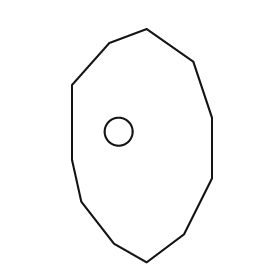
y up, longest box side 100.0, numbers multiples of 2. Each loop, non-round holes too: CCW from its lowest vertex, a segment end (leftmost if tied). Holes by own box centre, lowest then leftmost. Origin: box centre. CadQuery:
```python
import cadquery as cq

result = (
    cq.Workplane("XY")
    .moveTo(2.0, -50.0)
    .lineTo(18.0, -38.0)
    .lineTo(30.0, -14.0)
    .lineTo(30.0, 12.0)
    .lineTo(22.0, 36.0)
    .lineTo(2.0, 50.0)
    .lineTo(-14.0, 44.0)
    .lineTo(-30.0, 26.0)
    .lineTo(-30.0, -6.0)
    .lineTo(-26.0, -24.0)
    .lineTo(-12.0, -42.0)
    .close()
    .moveTo(-10.0, 6.0)
    .circle(6.0)
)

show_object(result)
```